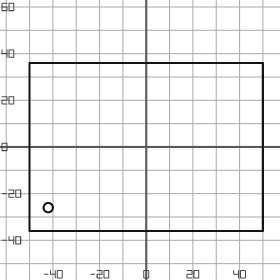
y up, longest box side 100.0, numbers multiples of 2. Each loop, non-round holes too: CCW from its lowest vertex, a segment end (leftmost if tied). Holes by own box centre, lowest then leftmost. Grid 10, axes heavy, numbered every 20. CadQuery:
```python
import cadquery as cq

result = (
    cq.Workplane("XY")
    .moveTo(-50.0, -36.0)
    .lineTo(50.0, -36.0)
    .lineTo(50.0, 36.0)
    .lineTo(-50.0, 36.0)
    .close()
    .moveTo(-42.0, -26.0)
    .circle(2.0)
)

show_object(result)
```